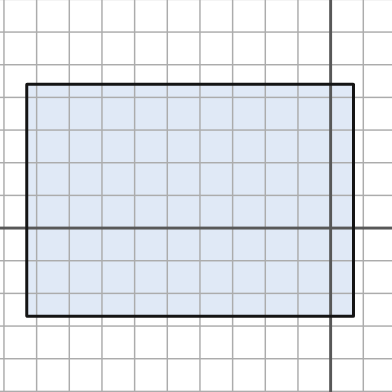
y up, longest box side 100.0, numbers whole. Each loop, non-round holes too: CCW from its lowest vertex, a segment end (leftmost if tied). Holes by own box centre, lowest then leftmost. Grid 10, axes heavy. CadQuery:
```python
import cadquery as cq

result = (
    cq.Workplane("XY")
    .moveTo(-93.0, -27.0)
    .lineTo(7.0, -27.0)
    .lineTo(7.0, 44.0)
    .lineTo(-93.0, 44.0)
    .close()
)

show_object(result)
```